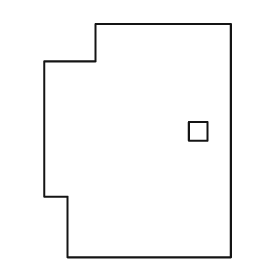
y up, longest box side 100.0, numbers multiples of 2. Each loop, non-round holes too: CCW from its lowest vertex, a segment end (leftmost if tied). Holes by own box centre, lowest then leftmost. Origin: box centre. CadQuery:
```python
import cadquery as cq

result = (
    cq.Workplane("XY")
    .moveTo(-30.0, -50.0)
    .lineTo(40.0, -50.0)
    .lineTo(40.0, 50.0)
    .lineTo(-18.0, 50.0)
    .lineTo(-18.0, 34.0)
    .lineTo(-40.0, 34.0)
    .lineTo(-40.0, -24.0)
    .lineTo(-30.0, -24.0)
    .close()
    .moveTo(22.0, 0.0)
    .lineTo(30.0, 0.0)
    .lineTo(30.0, 8.0)
    .lineTo(22.0, 8.0)
    .close()
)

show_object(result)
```